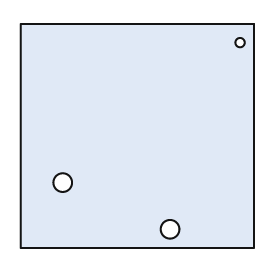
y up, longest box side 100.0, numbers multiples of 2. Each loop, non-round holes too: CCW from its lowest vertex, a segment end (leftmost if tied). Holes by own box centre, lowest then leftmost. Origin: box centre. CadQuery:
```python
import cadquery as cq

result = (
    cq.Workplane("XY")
    .moveTo(-50.0, -48.0)
    .lineTo(50.0, -48.0)
    .lineTo(50.0, 48.0)
    .lineTo(-50.0, 48.0)
    .close()
    .moveTo(14.0, -40.0)
    .circle(4.0)
    .moveTo(-32.0, -20.0)
    .circle(4.0)
    .moveTo(44.0, 40.0)
    .circle(2.0)
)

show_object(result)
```